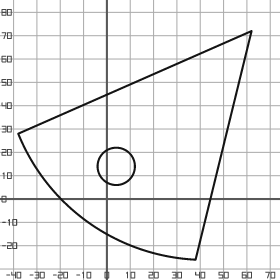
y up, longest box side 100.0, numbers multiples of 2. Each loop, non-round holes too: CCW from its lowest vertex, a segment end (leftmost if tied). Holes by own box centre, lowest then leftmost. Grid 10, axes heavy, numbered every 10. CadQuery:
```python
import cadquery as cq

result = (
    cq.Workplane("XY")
    .moveTo(38.0, -26.0)
    .lineTo(62.0, 72.0)
    .lineTo(-38.0, 28.0)
    .threePointArc((-8.0, -10.0), (38.0, -26.0))
    .close()
    .moveTo(4.0, 14.0)
    .circle(8.0)
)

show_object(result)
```